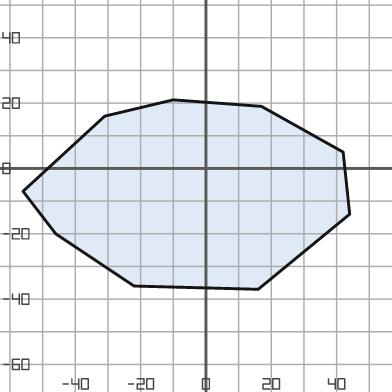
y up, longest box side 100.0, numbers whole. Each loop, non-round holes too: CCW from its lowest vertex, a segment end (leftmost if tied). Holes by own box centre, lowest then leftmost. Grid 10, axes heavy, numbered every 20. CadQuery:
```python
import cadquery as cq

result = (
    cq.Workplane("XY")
    .moveTo(16.0, -37.0)
    .lineTo(44.0, -14.0)
    .lineTo(42.0, 5.0)
    .lineTo(17.0, 19.0)
    .lineTo(-10.0, 21.0)
    .lineTo(-31.0, 16.0)
    .lineTo(-56.0, -7.0)
    .lineTo(-46.0, -20.0)
    .lineTo(-22.0, -36.0)
    .close()
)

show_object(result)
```